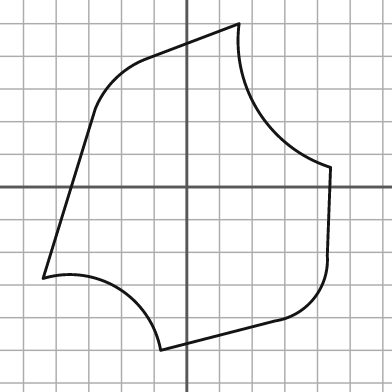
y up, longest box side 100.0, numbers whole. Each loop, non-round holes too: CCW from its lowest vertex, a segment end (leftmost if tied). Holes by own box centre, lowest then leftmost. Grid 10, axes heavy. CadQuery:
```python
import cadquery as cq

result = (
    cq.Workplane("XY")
    .moveTo(-8.0, -50.0)
    .lineTo(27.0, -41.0)
    .threePointArc((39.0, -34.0), (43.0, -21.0))
    .lineTo(44.0, 6.0)
    .threePointArc((22.0, 23.0), (16.0, 50.0))
    .lineTo(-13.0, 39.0)
    .threePointArc((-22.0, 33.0), (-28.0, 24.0))
    .lineTo(-44.0, -28.0)
    .threePointArc((-21.0, -31.0), (-8.0, -50.0))
    .close()
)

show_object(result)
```